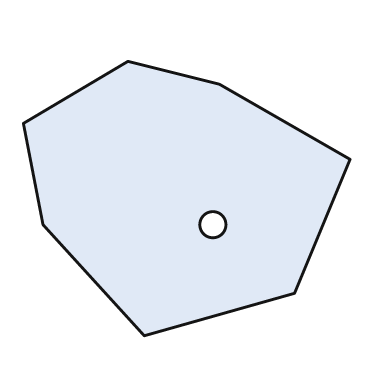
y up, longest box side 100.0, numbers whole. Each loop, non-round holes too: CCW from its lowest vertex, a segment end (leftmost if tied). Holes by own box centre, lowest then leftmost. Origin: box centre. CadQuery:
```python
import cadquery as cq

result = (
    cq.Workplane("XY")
    .moveTo(-13.0, -42.0)
    .lineTo(33.0, -29.0)
    .lineTo(50.0, 12.0)
    .lineTo(10.0, 35.0)
    .lineTo(-18.0, 42.0)
    .lineTo(-50.0, 23.0)
    .lineTo(-44.0, -8.0)
    .close()
    .moveTo(8.0, -8.0)
    .circle(4.0)
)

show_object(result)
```